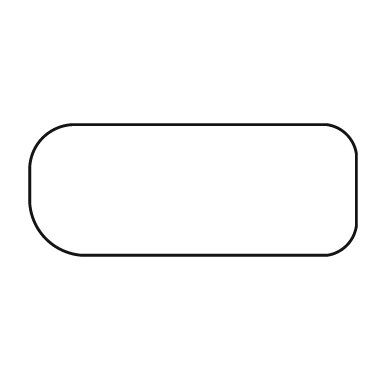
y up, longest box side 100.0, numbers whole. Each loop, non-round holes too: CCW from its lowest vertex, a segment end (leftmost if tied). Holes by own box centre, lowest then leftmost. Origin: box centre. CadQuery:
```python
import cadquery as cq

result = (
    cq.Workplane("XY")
    .moveTo(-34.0, -20.0)
    .lineTo(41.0, -20.0)
    .threePointArc((47.0, -17.0), (50.0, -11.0))
    .lineTo(50.0, 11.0)
    .threePointArc((47.0, 17.0), (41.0, 20.0))
    .lineTo(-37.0, 20.0)
    .threePointArc((-46.0, 16.0), (-50.0, 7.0))
    .lineTo(-50.0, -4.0)
    .threePointArc((-45.0, -15.0), (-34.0, -20.0))
    .close()
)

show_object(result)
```